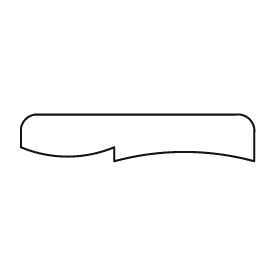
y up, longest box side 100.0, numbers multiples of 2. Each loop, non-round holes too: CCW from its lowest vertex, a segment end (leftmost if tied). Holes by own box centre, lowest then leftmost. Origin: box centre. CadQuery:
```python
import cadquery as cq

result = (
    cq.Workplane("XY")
    .moveTo(-10.0, -10.0)
    .threePointArc((20.0, -6.0), (50.0, -10.0))
    .lineTo(50.0, 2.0)
    .threePointArc((48.0, 8.0), (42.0, 10.0))
    .lineTo(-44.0, 10.0)
    .threePointArc((-48.0, 8.0), (-50.0, 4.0))
    .lineTo(-50.0, -4.0)
    .threePointArc((-30.0, -8.0), (-10.0, -4.0))
    .close()
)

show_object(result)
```